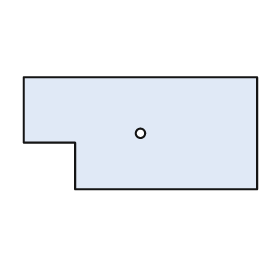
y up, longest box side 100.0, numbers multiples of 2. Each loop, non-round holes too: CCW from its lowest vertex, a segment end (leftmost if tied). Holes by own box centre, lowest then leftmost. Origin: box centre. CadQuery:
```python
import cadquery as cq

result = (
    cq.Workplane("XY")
    .moveTo(-28.0, -24.0)
    .lineTo(50.0, -24.0)
    .lineTo(50.0, 24.0)
    .lineTo(-50.0, 24.0)
    .lineTo(-50.0, -4.0)
    .lineTo(-28.0, -4.0)
    .close()
    .moveTo(0.0, 0.0)
    .circle(2.0)
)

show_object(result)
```